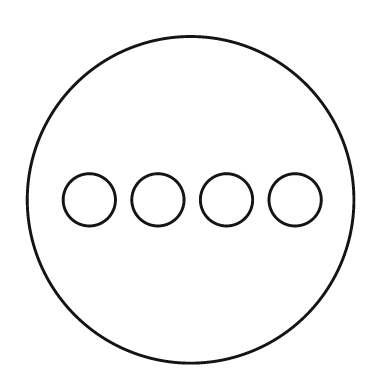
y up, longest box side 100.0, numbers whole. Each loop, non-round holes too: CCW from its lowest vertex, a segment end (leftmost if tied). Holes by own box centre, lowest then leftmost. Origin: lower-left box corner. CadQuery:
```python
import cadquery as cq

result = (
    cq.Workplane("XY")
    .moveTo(50.0, 50.0)
    .circle(50.0)
    .moveTo(19.0, 50.0)
    .circle(8.0)
    .moveTo(40.0, 50.0)
    .circle(8.0)
    .moveTo(61.0, 50.0)
    .circle(8.0)
    .moveTo(82.0, 50.0)
    .circle(8.0)
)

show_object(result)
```